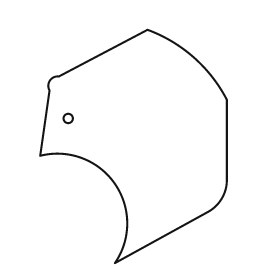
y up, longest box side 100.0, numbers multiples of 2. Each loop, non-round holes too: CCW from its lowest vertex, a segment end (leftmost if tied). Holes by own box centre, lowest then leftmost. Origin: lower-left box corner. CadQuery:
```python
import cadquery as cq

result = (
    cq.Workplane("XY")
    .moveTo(32.0, 0.0)
    .lineTo(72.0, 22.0)
    .threePointArc((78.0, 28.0), (80.0, 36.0))
    .lineTo(80.0, 70.0)
    .threePointArc((66.0, 88.0), (46.0, 100.0))
    .lineTo(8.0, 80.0)
    .threePointArc((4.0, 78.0), (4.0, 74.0))
    .lineTo(0.0, 46.0)
    .threePointArc((32.0, 34.0), (32.0, 0.0))
    .close()
    .moveTo(12.0, 62.0)
    .circle(2.0)
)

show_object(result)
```